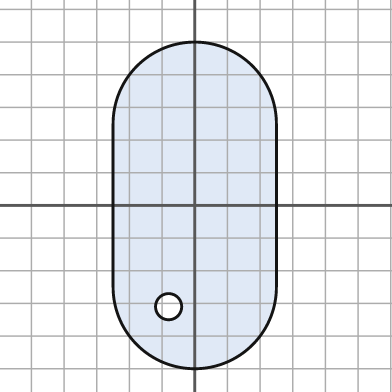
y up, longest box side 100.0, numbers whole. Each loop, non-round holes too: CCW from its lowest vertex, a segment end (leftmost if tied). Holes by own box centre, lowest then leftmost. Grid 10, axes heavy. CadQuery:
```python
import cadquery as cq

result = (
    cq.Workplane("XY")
    .moveTo(-25.0, -25.0)
    .threePointArc((0.0, -50.0), (25.0, -25.0))
    .lineTo(25.0, 25.0)
    .threePointArc((0.0, 50.0), (-25.0, 25.0))
    .close()
    .moveTo(-8.0, -31.0)
    .circle(4.0)
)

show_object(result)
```